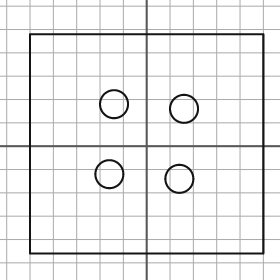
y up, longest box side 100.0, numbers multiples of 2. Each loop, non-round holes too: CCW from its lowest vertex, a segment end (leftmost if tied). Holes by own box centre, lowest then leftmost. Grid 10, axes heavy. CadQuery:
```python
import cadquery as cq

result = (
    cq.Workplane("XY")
    .moveTo(-50.0, -46.0)
    .lineTo(50.0, -46.0)
    .lineTo(50.0, 48.0)
    .lineTo(-50.0, 48.0)
    .close()
    .moveTo(14.0, -14.0)
    .circle(6.0)
    .moveTo(-16.0, -12.0)
    .circle(6.0)
    .moveTo(16.0, 16.0)
    .circle(6.0)
    .moveTo(-14.0, 18.0)
    .circle(6.0)
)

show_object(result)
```